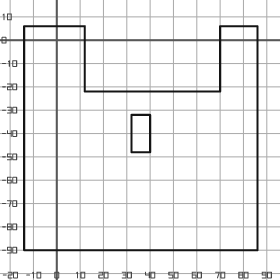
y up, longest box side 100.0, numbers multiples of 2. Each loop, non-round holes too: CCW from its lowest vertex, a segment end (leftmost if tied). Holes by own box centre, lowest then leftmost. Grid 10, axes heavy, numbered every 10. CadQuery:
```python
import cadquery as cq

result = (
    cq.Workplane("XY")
    .moveTo(-14.0, -90.0)
    .lineTo(86.0, -90.0)
    .lineTo(86.0, 6.0)
    .lineTo(70.0, 6.0)
    .lineTo(70.0, -22.0)
    .lineTo(12.0, -22.0)
    .lineTo(12.0, 6.0)
    .lineTo(-14.0, 6.0)
    .close()
    .moveTo(32.0, -48.0)
    .lineTo(40.0, -48.0)
    .lineTo(40.0, -32.0)
    .lineTo(32.0, -32.0)
    .close()
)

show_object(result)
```